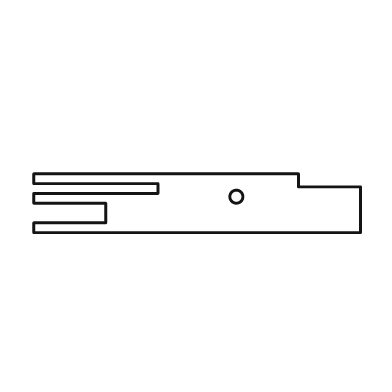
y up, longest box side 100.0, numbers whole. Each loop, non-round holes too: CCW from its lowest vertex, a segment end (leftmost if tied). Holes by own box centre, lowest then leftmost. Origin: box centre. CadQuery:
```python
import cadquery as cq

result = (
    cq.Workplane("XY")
    .moveTo(-50.0, -9.0)
    .lineTo(50.0, -9.0)
    .lineTo(50.0, 5.0)
    .lineTo(31.0, 5.0)
    .lineTo(31.0, 9.0)
    .lineTo(-50.0, 9.0)
    .lineTo(-50.0, 6.0)
    .lineTo(-12.0, 6.0)
    .lineTo(-12.0, 3.0)
    .lineTo(-50.0, 3.0)
    .lineTo(-50.0, 0.0)
    .lineTo(-28.0, 0.0)
    .lineTo(-28.0, -6.0)
    .lineTo(-50.0, -6.0)
    .close()
    .moveTo(12.0, 2.0)
    .circle(2.0)
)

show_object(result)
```